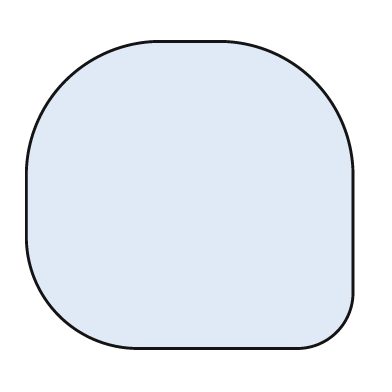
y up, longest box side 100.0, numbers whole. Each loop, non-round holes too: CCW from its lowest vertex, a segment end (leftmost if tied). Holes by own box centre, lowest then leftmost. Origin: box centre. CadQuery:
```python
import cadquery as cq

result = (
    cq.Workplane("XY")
    .moveTo(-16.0, -47.0)
    .lineTo(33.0, -47.0)
    .threePointArc((45.0, -42.0), (50.0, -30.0))
    .lineTo(50.0, 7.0)
    .threePointArc((38.0, 35.0), (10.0, 47.0))
    .lineTo(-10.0, 47.0)
    .threePointArc((-38.0, 35.0), (-50.0, 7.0))
    .lineTo(-50.0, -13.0)
    .threePointArc((-40.0, -37.0), (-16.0, -47.0))
    .close()
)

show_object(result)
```